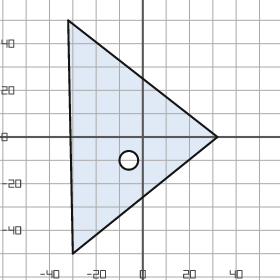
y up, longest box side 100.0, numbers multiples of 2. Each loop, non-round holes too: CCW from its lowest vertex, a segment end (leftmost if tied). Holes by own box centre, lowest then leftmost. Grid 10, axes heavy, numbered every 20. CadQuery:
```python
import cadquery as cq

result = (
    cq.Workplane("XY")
    .moveTo(-30.0, -50.0)
    .lineTo(32.0, 0.0)
    .lineTo(-32.0, 50.0)
    .close()
    .moveTo(-6.0, -10.0)
    .circle(4.0)
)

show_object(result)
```